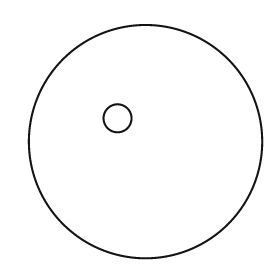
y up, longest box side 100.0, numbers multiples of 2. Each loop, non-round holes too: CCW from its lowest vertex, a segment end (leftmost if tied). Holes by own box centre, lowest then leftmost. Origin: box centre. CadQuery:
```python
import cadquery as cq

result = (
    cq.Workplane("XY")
    .moveTo(0.0, 0.0)
    .circle(50.0)
    .moveTo(-12.0, 10.0)
    .circle(6.0)
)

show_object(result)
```